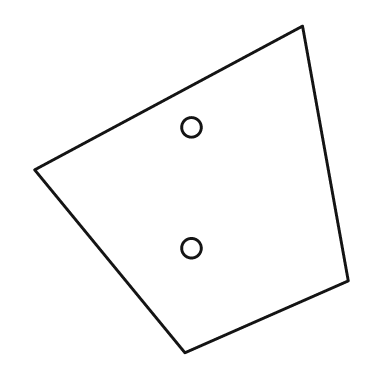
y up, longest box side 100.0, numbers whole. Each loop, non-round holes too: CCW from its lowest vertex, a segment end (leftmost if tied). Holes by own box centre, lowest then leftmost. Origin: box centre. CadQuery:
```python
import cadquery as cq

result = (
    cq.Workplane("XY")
    .moveTo(-2.0, -50.0)
    .lineTo(48.0, -28.0)
    .lineTo(34.0, 50.0)
    .lineTo(-48.0, 6.0)
    .close()
    .moveTo(0.0, -18.0)
    .circle(3.0)
    .moveTo(0.0, 19.0)
    .circle(3.0)
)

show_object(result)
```